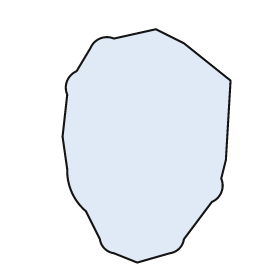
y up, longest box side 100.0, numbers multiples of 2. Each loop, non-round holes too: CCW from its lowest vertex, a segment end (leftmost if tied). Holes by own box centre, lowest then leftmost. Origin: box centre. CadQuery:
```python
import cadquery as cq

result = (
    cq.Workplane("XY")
    .moveTo(-4.0, -50.0)
    .lineTo(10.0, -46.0)
    .threePointArc((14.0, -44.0), (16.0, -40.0))
    .lineTo(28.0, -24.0)
    .threePointArc((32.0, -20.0), (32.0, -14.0))
    .lineTo(34.0, -6.0)
    .lineTo(36.0, 28.0)
    .lineTo(16.0, 44.0)
    .lineTo(4.0, 50.0)
    .lineTo(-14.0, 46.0)
    .threePointArc((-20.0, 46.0), (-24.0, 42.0))
    .lineTo(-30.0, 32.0)
    .threePointArc((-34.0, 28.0), (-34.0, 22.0))
    .lineTo(-36.0, 4.0)
    .lineTo(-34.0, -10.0)
    .threePointArc((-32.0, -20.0), (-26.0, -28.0))
    .lineTo(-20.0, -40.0)
    .threePointArc((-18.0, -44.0), (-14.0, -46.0))
    .close()
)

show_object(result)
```